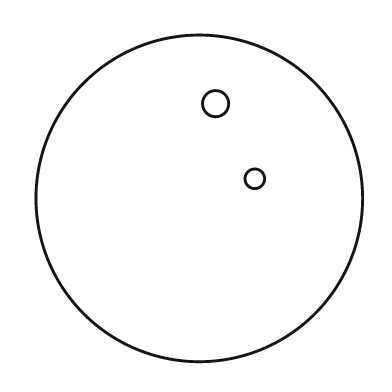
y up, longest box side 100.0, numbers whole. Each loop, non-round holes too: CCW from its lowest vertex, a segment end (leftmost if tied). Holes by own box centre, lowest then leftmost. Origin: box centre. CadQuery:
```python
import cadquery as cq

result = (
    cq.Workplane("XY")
    .moveTo(0.0, 0.0)
    .circle(50.0)
    .moveTo(17.0, 6.0)
    .circle(3.0)
    .moveTo(5.0, 29.0)
    .circle(4.0)
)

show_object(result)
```